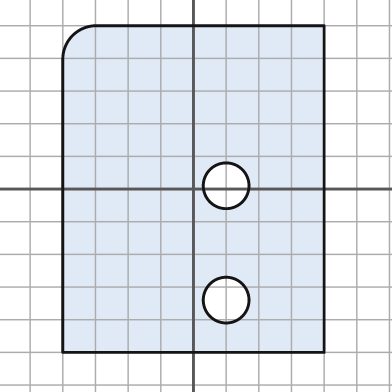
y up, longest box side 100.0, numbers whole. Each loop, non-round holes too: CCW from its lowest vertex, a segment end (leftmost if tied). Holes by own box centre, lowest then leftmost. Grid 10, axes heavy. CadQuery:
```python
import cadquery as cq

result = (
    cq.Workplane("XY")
    .moveTo(-40.0, -50.0)
    .lineTo(40.0, -50.0)
    .lineTo(40.0, 50.0)
    .lineTo(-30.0, 50.0)
    .threePointArc((-37.0, 47.0), (-40.0, 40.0))
    .close()
    .moveTo(10.0, -34.0)
    .circle(7.0)
    .moveTo(10.0, 1.0)
    .circle(7.0)
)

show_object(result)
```